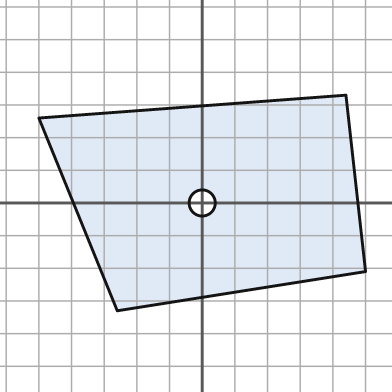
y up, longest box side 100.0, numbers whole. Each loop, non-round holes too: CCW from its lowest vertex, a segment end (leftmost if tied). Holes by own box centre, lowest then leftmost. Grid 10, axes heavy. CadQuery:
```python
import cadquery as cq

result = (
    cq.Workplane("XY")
    .moveTo(-26.0, -33.0)
    .lineTo(50.0, -21.0)
    .lineTo(44.0, 33.0)
    .lineTo(-50.0, 26.0)
    .close()
    .moveTo(0.0, 0.0)
    .circle(4.0)
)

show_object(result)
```